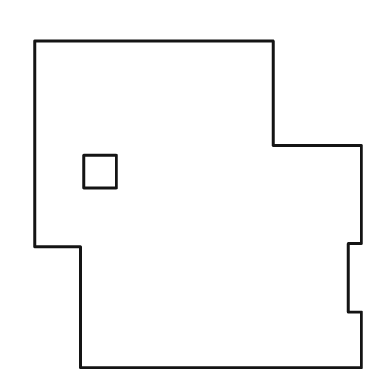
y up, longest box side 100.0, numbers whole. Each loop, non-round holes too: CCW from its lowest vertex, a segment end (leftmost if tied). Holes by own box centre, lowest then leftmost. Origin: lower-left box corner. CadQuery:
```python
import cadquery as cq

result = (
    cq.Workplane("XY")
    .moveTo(14.0, 0.0)
    .lineTo(100.0, 0.0)
    .lineTo(100.0, 17.0)
    .lineTo(96.0, 17.0)
    .lineTo(96.0, 38.0)
    .lineTo(100.0, 38.0)
    .lineTo(100.0, 68.0)
    .lineTo(73.0, 68.0)
    .lineTo(73.0, 100.0)
    .lineTo(0.0, 100.0)
    .lineTo(0.0, 37.0)
    .lineTo(14.0, 37.0)
    .close()
    .moveTo(15.0, 55.0)
    .lineTo(25.0, 55.0)
    .lineTo(25.0, 65.0)
    .lineTo(15.0, 65.0)
    .close()
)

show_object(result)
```